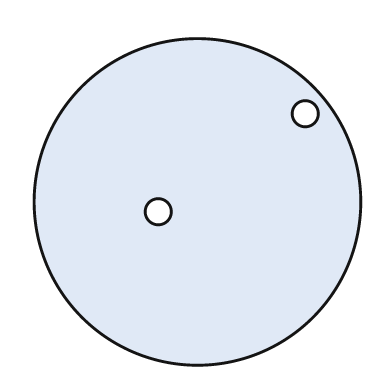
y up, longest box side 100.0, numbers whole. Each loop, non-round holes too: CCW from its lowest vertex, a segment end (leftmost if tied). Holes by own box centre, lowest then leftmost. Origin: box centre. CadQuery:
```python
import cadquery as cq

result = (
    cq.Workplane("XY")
    .moveTo(0.0, 0.0)
    .circle(50.0)
    .moveTo(-12.0, -3.0)
    .circle(4.0)
    .moveTo(33.0, 27.0)
    .circle(4.0)
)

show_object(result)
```